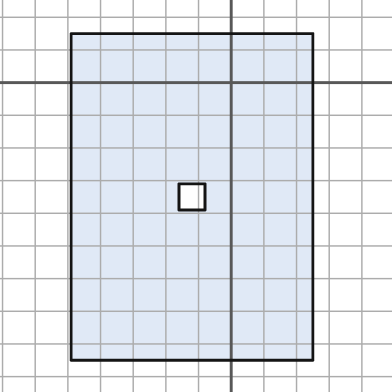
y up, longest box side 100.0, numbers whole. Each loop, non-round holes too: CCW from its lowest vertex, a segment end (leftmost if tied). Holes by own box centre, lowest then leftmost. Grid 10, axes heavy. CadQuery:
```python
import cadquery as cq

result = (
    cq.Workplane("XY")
    .moveTo(-49.0, -85.0)
    .lineTo(25.0, -85.0)
    .lineTo(25.0, 15.0)
    .lineTo(-49.0, 15.0)
    .close()
    .moveTo(-16.0, -39.0)
    .lineTo(-8.0, -39.0)
    .lineTo(-8.0, -31.0)
    .lineTo(-16.0, -31.0)
    .close()
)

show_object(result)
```